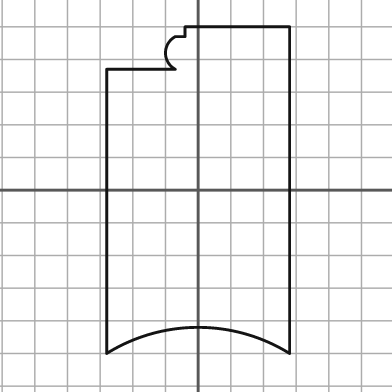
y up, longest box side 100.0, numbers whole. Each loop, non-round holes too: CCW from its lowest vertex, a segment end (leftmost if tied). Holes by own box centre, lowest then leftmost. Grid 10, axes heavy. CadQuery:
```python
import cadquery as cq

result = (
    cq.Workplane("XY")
    .moveTo(-28.0, -50.0)
    .threePointArc((0.0, -42.0), (28.0, -50.0))
    .lineTo(28.0, 50.0)
    .lineTo(-4.0, 50.0)
    .lineTo(-4.0, 47.0)
    .lineTo(-7.0, 47.0)
    .threePointArc((-10.0, 42.0), (-7.0, 37.0))
    .lineTo(-28.0, 37.0)
    .close()
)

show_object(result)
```